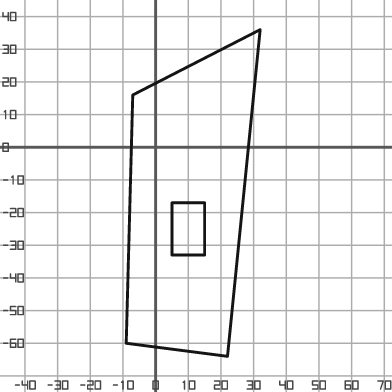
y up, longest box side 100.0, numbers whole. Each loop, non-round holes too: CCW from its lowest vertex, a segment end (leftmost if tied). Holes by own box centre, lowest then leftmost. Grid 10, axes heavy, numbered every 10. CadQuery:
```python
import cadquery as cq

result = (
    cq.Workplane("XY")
    .moveTo(22.0, -64.0)
    .lineTo(32.0, 36.0)
    .lineTo(-7.0, 16.0)
    .lineTo(-9.0, -60.0)
    .close()
    .moveTo(5.0, -33.0)
    .lineTo(15.0, -33.0)
    .lineTo(15.0, -17.0)
    .lineTo(5.0, -17.0)
    .close()
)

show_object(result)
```